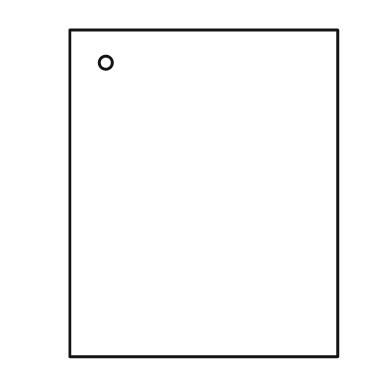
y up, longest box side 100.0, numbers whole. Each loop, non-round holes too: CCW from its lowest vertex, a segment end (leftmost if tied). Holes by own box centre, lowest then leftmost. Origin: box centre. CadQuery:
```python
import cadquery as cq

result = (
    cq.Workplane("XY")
    .moveTo(-41.0, -50.0)
    .lineTo(41.0, -50.0)
    .lineTo(41.0, 50.0)
    .lineTo(-41.0, 50.0)
    .close()
    .moveTo(-30.0, 40.0)
    .circle(2.0)
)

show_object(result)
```